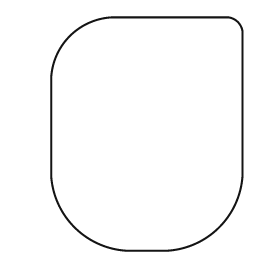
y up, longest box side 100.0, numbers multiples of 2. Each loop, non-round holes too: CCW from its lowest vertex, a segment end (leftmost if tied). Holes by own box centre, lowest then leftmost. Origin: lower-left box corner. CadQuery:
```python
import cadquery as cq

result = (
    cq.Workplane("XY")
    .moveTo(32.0, 0.0)
    .lineTo(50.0, 0.0)
    .threePointArc((72.0, 10.0), (82.0, 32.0))
    .lineTo(82.0, 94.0)
    .threePointArc((80.0, 98.0), (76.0, 100.0))
    .lineTo(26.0, 100.0)
    .threePointArc((8.0, 92.0), (0.0, 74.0))
    .lineTo(0.0, 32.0)
    .threePointArc((10.0, 10.0), (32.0, 0.0))
    .close()
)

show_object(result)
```